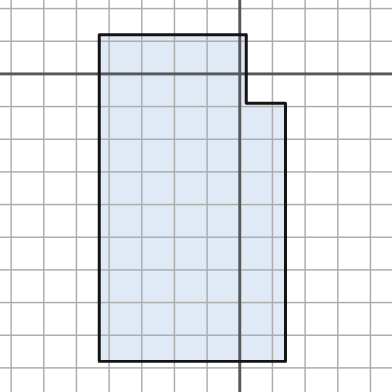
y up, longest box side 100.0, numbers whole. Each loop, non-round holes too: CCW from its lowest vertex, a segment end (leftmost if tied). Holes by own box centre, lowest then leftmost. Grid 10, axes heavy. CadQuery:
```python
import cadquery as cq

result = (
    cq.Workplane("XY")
    .moveTo(-43.0, -88.0)
    .lineTo(14.0, -88.0)
    .lineTo(14.0, -9.0)
    .lineTo(2.0, -9.0)
    .lineTo(2.0, 12.0)
    .lineTo(-43.0, 12.0)
    .close()
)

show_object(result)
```